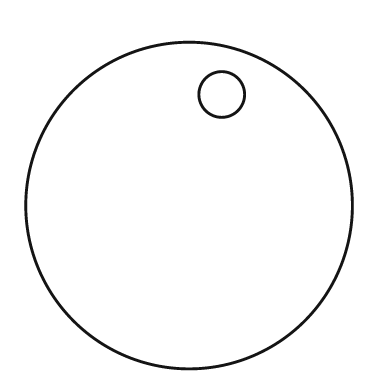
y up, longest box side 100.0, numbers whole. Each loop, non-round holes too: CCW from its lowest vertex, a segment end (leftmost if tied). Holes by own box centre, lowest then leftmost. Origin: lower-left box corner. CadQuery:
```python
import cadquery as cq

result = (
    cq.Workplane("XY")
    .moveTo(50.0, 50.0)
    .circle(50.0)
    .moveTo(60.0, 84.0)
    .circle(7.0)
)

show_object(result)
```